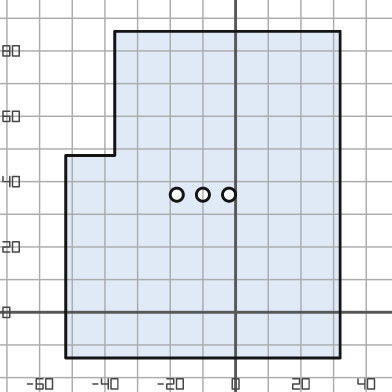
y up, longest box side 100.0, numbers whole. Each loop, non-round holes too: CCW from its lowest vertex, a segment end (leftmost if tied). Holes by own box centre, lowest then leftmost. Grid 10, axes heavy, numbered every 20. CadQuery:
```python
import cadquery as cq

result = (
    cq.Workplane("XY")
    .moveTo(-52.0, -14.0)
    .lineTo(32.0, -14.0)
    .lineTo(32.0, 86.0)
    .lineTo(-37.0, 86.0)
    .lineTo(-37.0, 48.0)
    .lineTo(-52.0, 48.0)
    .close()
    .moveTo(-18.0, 36.0)
    .circle(2.0)
    .moveTo(-10.0, 36.0)
    .circle(2.0)
    .moveTo(-2.0, 36.0)
    .circle(2.0)
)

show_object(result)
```